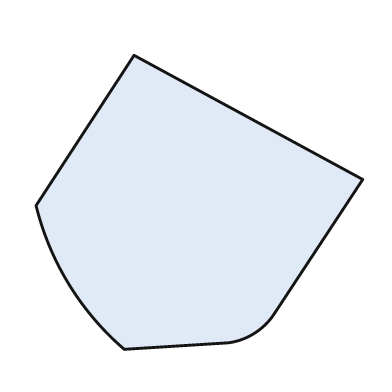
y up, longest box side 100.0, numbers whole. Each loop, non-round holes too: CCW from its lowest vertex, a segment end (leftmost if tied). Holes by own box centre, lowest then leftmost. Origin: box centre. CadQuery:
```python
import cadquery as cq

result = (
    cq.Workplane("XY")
    .moveTo(-23.0, -45.0)
    .lineTo(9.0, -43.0)
    .threePointArc((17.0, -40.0), (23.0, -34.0))
    .lineTo(50.0, 7.0)
    .lineTo(-20.0, 45.0)
    .lineTo(-50.0, -1.0)
    .threePointArc((-40.0, -25.0), (-23.0, -45.0))
    .close()
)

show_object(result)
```